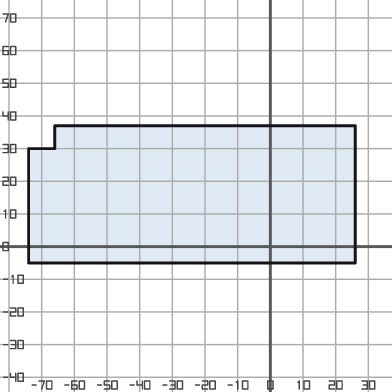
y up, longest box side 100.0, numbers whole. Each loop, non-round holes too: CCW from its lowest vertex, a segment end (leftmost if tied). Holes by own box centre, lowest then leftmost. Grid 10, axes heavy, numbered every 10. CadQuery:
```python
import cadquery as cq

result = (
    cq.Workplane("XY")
    .moveTo(-74.0, -5.0)
    .lineTo(26.0, -5.0)
    .lineTo(26.0, 37.0)
    .lineTo(-66.0, 37.0)
    .lineTo(-66.0, 30.0)
    .lineTo(-74.0, 30.0)
    .close()
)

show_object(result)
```